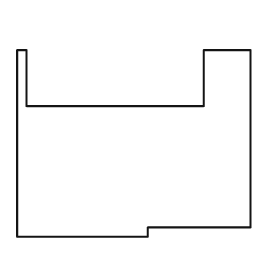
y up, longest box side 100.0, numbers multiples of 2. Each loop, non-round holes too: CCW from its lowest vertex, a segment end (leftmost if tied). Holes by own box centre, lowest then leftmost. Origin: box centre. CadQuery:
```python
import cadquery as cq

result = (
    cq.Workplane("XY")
    .moveTo(-50.0, -40.0)
    .lineTo(6.0, -40.0)
    .lineTo(6.0, -36.0)
    .lineTo(50.0, -36.0)
    .lineTo(50.0, 40.0)
    .lineTo(30.0, 40.0)
    .lineTo(30.0, 16.0)
    .lineTo(-46.0, 16.0)
    .lineTo(-46.0, 40.0)
    .lineTo(-50.0, 40.0)
    .close()
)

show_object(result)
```